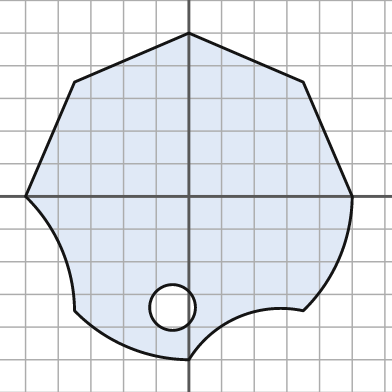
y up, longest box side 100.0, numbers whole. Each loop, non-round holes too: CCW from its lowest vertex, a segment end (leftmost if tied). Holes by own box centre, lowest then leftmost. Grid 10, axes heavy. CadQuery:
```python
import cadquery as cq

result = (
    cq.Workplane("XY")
    .moveTo(0.0, -50.0)
    .threePointArc((15.0, -37.0), (35.0, -35.0))
    .threePointArc((46.0, -19.0), (50.0, 0.0))
    .lineTo(35.0, 35.0)
    .lineTo(0.0, 50.0)
    .lineTo(-35.0, 35.0)
    .lineTo(-50.0, 0.0)
    .threePointArc((-39.0, -16.0), (-35.0, -35.0))
    .threePointArc((-19.0, -46.0), (0.0, -50.0))
    .close()
    .moveTo(-5.0, -34.0)
    .circle(7.0)
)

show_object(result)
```